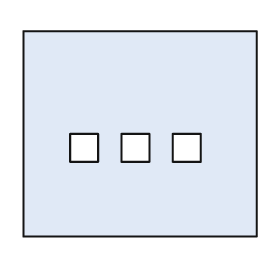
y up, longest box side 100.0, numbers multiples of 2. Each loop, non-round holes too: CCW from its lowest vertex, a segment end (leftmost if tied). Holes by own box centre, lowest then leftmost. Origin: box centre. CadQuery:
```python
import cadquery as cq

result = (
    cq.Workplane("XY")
    .moveTo(-50.0, -44.0)
    .lineTo(50.0, -44.0)
    .lineTo(50.0, 44.0)
    .lineTo(-50.0, 44.0)
    .close()
    .moveTo(-30.0, -12.0)
    .lineTo(-18.0, -12.0)
    .lineTo(-18.0, 0.0)
    .lineTo(-30.0, 0.0)
    .close()
    .moveTo(-8.0, -12.0)
    .lineTo(4.0, -12.0)
    .lineTo(4.0, 0.0)
    .lineTo(-8.0, 0.0)
    .close()
    .moveTo(14.0, -12.0)
    .lineTo(26.0, -12.0)
    .lineTo(26.0, 0.0)
    .lineTo(14.0, 0.0)
    .close()
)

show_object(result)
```